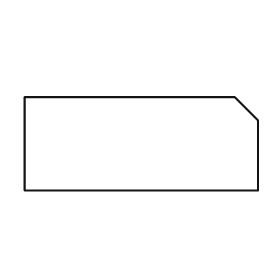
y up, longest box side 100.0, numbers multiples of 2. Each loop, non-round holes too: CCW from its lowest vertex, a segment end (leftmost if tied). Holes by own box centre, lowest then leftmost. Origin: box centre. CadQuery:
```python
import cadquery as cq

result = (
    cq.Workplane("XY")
    .moveTo(-50.0, -20.0)
    .lineTo(50.0, -20.0)
    .lineTo(50.0, 10.0)
    .lineTo(40.0, 20.0)
    .lineTo(-50.0, 20.0)
    .close()
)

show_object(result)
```